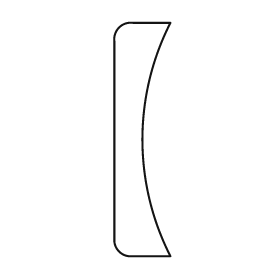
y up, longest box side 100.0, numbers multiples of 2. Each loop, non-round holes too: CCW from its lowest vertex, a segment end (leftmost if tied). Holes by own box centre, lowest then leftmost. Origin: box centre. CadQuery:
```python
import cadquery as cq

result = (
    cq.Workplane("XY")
    .moveTo(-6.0, -50.0)
    .lineTo(12.0, -50.0)
    .threePointArc((0.0, 0.0), (12.0, 50.0))
    .lineTo(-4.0, 50.0)
    .threePointArc((-10.0, 48.0), (-12.0, 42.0))
    .lineTo(-12.0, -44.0)
    .threePointArc((-10.0, -48.0), (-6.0, -50.0))
    .close()
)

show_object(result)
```